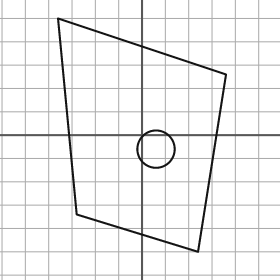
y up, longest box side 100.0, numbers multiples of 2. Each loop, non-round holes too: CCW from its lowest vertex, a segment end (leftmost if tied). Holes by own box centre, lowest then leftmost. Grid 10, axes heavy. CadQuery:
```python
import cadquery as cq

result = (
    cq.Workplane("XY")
    .moveTo(24.0, -50.0)
    .lineTo(36.0, 26.0)
    .lineTo(-36.0, 50.0)
    .lineTo(-28.0, -34.0)
    .close()
    .moveTo(6.0, -6.0)
    .circle(8.0)
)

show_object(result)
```